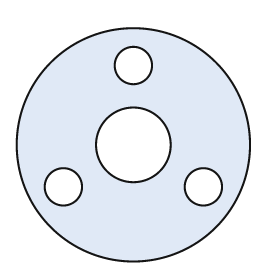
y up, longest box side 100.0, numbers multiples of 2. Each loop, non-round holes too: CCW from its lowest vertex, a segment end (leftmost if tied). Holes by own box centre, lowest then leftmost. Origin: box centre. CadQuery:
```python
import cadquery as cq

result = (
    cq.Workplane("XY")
    .moveTo(0.0, 0.0)
    .circle(50.0)
    .moveTo(-30.0, -18.0)
    .circle(8.0)
    .moveTo(30.0, -18.0)
    .circle(8.0)
    .moveTo(0.0, 0.0)
    .circle(16.0)
    .moveTo(0.0, 34.0)
    .circle(8.0)
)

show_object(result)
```